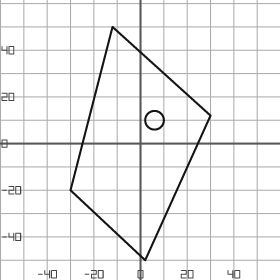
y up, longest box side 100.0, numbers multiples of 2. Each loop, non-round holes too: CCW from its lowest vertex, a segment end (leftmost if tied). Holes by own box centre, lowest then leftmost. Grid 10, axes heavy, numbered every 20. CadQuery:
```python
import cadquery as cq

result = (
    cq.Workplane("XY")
    .moveTo(2.0, -50.0)
    .lineTo(30.0, 12.0)
    .lineTo(-12.0, 50.0)
    .lineTo(-30.0, -20.0)
    .close()
    .moveTo(6.0, 10.0)
    .circle(4.0)
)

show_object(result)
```